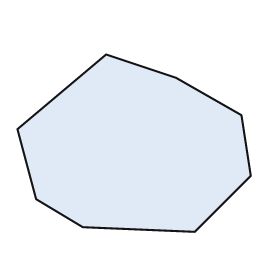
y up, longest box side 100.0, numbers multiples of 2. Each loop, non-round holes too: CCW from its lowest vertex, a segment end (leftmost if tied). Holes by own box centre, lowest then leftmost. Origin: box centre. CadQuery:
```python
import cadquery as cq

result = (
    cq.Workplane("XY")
    .moveTo(26.0, -38.0)
    .lineTo(50.0, -14.0)
    .lineTo(46.0, 12.0)
    .lineTo(18.0, 28.0)
    .lineTo(-12.0, 38.0)
    .lineTo(-50.0, 6.0)
    .lineTo(-42.0, -24.0)
    .lineTo(-22.0, -36.0)
    .close()
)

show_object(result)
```